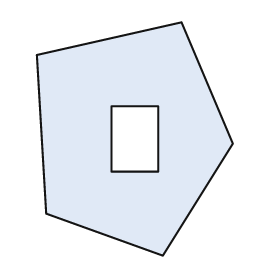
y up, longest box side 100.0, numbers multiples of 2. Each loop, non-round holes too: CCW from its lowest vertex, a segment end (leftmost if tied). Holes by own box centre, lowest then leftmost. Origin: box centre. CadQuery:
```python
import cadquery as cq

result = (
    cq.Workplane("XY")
    .moveTo(12.0, -50.0)
    .lineTo(42.0, -2.0)
    .lineTo(20.0, 50.0)
    .lineTo(-42.0, 36.0)
    .lineTo(-38.0, -32.0)
    .close()
    .moveTo(-10.0, -14.0)
    .lineTo(10.0, -14.0)
    .lineTo(10.0, 14.0)
    .lineTo(-10.0, 14.0)
    .close()
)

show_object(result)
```